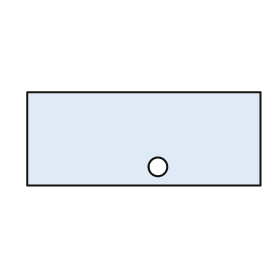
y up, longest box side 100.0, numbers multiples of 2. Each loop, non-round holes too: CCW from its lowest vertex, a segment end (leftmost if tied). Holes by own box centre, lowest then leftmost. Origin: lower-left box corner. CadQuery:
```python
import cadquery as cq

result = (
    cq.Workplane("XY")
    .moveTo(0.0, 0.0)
    .lineTo(100.0, 0.0)
    .lineTo(100.0, 40.0)
    .lineTo(0.0, 40.0)
    .close()
    .moveTo(56.0, 8.0)
    .circle(4.0)
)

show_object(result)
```